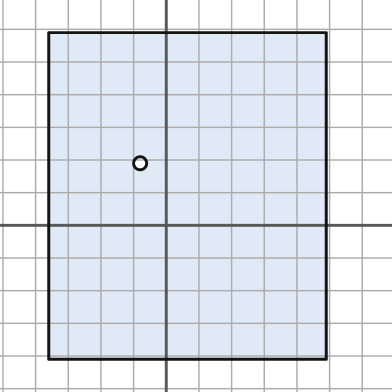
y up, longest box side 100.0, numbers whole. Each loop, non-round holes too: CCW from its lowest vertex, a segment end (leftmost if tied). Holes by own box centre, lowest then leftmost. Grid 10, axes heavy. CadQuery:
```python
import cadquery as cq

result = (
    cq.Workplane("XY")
    .moveTo(-36.0, -41.0)
    .lineTo(49.0, -41.0)
    .lineTo(49.0, 59.0)
    .lineTo(-36.0, 59.0)
    .close()
    .moveTo(-8.0, 19.0)
    .circle(2.0)
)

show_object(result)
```